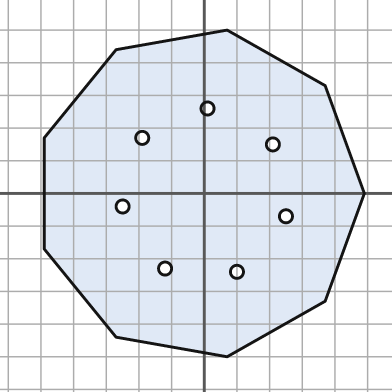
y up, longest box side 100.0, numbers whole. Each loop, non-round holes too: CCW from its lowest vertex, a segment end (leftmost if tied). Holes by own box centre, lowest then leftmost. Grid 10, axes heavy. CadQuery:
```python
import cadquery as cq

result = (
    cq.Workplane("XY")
    .moveTo(7.0, -50.0)
    .lineTo(37.0, -33.0)
    .lineTo(49.0, 0.0)
    .lineTo(37.0, 33.0)
    .lineTo(7.0, 50.0)
    .lineTo(-27.0, 44.0)
    .lineTo(-49.0, 17.0)
    .lineTo(-49.0, -17.0)
    .lineTo(-27.0, -44.0)
    .close()
    .moveTo(10.0, -24.0)
    .circle(2.0)
    .moveTo(-12.0, -23.0)
    .circle(2.0)
    .moveTo(25.0, -7.0)
    .circle(2.0)
    .moveTo(-25.0, -4.0)
    .circle(2.0)
    .moveTo(21.0, 15.0)
    .circle(2.0)
    .moveTo(-19.0, 17.0)
    .circle(2.0)
    .moveTo(1.0, 26.0)
    .circle(2.0)
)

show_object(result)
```